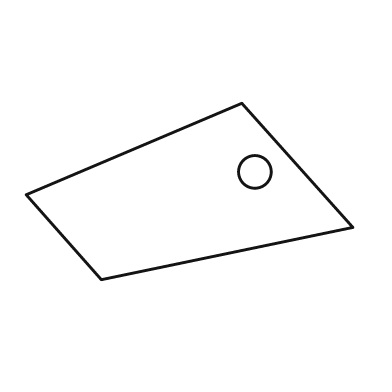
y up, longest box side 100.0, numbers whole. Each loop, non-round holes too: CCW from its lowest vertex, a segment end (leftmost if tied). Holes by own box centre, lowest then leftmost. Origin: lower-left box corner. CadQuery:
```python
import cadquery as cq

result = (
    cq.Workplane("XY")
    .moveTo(23.0, 0.0)
    .lineTo(100.0, 16.0)
    .lineTo(66.0, 54.0)
    .lineTo(0.0, 26.0)
    .close()
    .moveTo(70.0, 33.0)
    .circle(5.0)
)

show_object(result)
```